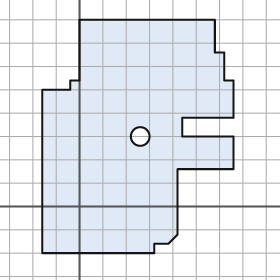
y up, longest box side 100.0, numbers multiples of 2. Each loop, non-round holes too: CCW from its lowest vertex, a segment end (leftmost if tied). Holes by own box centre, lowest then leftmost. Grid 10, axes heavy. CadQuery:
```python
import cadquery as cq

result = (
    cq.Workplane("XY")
    .moveTo(-16.0, -20.0)
    .lineTo(32.0, -20.0)
    .lineTo(32.0, -16.0)
    .lineTo(38.0, -16.0)
    .lineTo(42.0, -12.0)
    .lineTo(42.0, 16.0)
    .lineTo(66.0, 16.0)
    .lineTo(66.0, 30.0)
    .lineTo(44.0, 30.0)
    .lineTo(44.0, 38.0)
    .lineTo(66.0, 38.0)
    .lineTo(66.0, 54.0)
    .lineTo(62.0, 54.0)
    .lineTo(62.0, 66.0)
    .lineTo(58.0, 66.0)
    .lineTo(58.0, 80.0)
    .lineTo(0.0, 80.0)
    .lineTo(0.0, 54.0)
    .lineTo(-4.0, 54.0)
    .lineTo(-4.0, 50.0)
    .lineTo(-16.0, 50.0)
    .close()
    .moveTo(26.0, 30.0)
    .circle(4.0)
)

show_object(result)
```